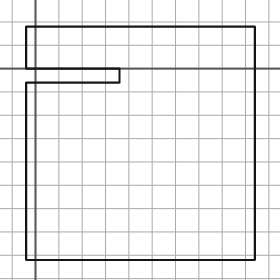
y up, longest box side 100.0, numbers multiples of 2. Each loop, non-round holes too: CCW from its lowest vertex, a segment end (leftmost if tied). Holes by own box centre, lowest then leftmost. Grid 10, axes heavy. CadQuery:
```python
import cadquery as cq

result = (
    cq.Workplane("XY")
    .moveTo(-4.0, -82.0)
    .lineTo(94.0, -82.0)
    .lineTo(94.0, 18.0)
    .lineTo(-4.0, 18.0)
    .lineTo(-4.0, 0.0)
    .lineTo(36.0, 0.0)
    .lineTo(36.0, -6.0)
    .lineTo(-4.0, -6.0)
    .close()
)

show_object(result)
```